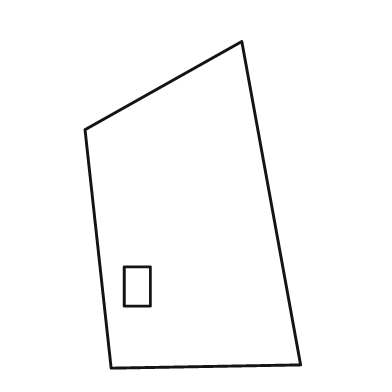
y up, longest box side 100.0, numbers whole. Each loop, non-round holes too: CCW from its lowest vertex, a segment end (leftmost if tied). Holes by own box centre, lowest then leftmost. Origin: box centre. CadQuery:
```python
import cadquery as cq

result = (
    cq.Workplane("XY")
    .moveTo(-25.0, -50.0)
    .lineTo(33.0, -49.0)
    .lineTo(15.0, 50.0)
    .lineTo(-33.0, 23.0)
    .close()
    .moveTo(-21.0, -31.0)
    .lineTo(-13.0, -31.0)
    .lineTo(-13.0, -19.0)
    .lineTo(-21.0, -19.0)
    .close()
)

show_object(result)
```